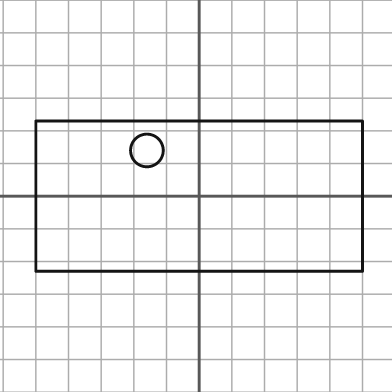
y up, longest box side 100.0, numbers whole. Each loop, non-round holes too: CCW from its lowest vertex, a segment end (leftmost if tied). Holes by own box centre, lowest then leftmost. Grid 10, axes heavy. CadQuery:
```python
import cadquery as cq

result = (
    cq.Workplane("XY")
    .moveTo(-50.0, -23.0)
    .lineTo(50.0, -23.0)
    .lineTo(50.0, 23.0)
    .lineTo(-50.0, 23.0)
    .close()
    .moveTo(-16.0, 14.0)
    .circle(5.0)
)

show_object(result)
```